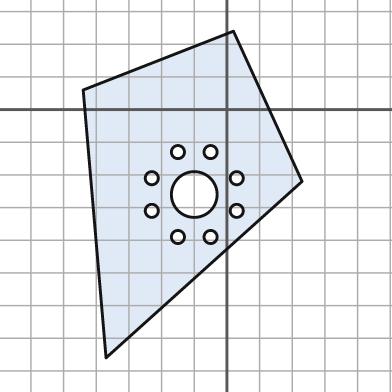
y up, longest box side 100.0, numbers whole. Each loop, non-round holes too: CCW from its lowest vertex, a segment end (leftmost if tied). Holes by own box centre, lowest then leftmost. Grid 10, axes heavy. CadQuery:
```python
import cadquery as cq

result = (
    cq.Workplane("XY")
    .moveTo(-37.0, -76.0)
    .lineTo(23.0, -22.0)
    .lineTo(2.0, 24.0)
    .lineTo(-44.0, 6.0)
    .close()
    .moveTo(-15.0, -39.0)
    .circle(2.0)
    .moveTo(-5.0, -39.0)
    .circle(2.0)
    .moveTo(-23.0, -31.0)
    .circle(2.0)
    .moveTo(3.0, -31.0)
    .circle(2.0)
    .moveTo(-10.0, -26.0)
    .circle(7.0)
    .moveTo(-23.0, -21.0)
    .circle(2.0)
    .moveTo(3.0, -21.0)
    .circle(2.0)
    .moveTo(-15.0, -13.0)
    .circle(2.0)
    .moveTo(-5.0, -13.0)
    .circle(2.0)
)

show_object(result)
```